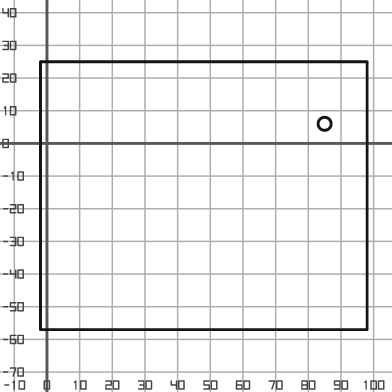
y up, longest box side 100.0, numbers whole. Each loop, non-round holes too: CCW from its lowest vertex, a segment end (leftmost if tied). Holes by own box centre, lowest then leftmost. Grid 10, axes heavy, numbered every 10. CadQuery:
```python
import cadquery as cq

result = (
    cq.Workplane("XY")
    .moveTo(-2.0, -57.0)
    .lineTo(98.0, -57.0)
    .lineTo(98.0, 25.0)
    .lineTo(-2.0, 25.0)
    .close()
    .moveTo(85.0, 6.0)
    .circle(2.0)
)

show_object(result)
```